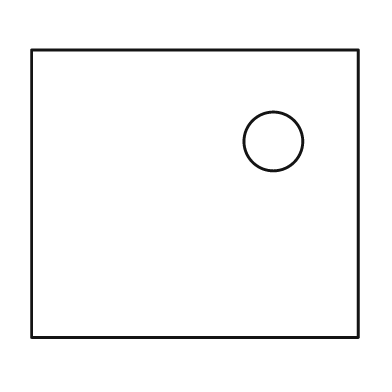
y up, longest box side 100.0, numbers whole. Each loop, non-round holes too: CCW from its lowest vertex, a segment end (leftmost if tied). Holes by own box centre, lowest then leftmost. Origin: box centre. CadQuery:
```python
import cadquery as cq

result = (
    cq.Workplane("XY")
    .moveTo(-50.0, -44.0)
    .lineTo(50.0, -44.0)
    .lineTo(50.0, 44.0)
    .lineTo(-50.0, 44.0)
    .close()
    .moveTo(24.0, 16.0)
    .circle(9.0)
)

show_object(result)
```